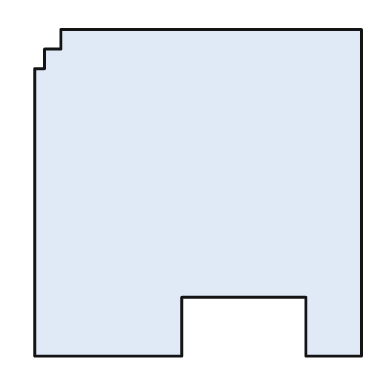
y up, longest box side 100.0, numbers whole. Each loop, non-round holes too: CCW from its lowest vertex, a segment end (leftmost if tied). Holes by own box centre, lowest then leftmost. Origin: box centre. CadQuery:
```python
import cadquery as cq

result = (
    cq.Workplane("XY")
    .moveTo(-50.0, -50.0)
    .lineTo(-5.0, -50.0)
    .lineTo(-5.0, -32.0)
    .lineTo(33.0, -32.0)
    .lineTo(33.0, -50.0)
    .lineTo(50.0, -50.0)
    .lineTo(50.0, 50.0)
    .lineTo(-42.0, 50.0)
    .lineTo(-42.0, 44.0)
    .lineTo(-47.0, 44.0)
    .lineTo(-47.0, 38.0)
    .lineTo(-50.0, 38.0)
    .close()
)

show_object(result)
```